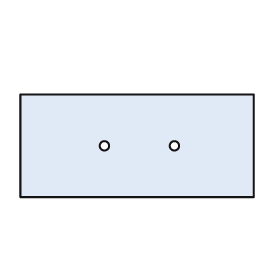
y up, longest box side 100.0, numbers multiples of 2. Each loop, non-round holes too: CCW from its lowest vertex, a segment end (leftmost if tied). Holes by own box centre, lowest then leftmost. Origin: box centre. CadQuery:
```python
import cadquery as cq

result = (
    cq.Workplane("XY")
    .moveTo(-50.0, -22.0)
    .lineTo(50.0, -22.0)
    .lineTo(50.0, 22.0)
    .lineTo(-50.0, 22.0)
    .close()
    .moveTo(-14.0, 0.0)
    .circle(2.0)
    .moveTo(16.0, 0.0)
    .circle(2.0)
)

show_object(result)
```